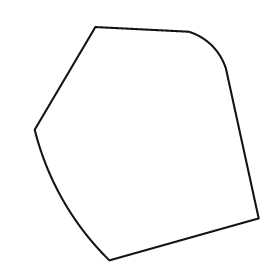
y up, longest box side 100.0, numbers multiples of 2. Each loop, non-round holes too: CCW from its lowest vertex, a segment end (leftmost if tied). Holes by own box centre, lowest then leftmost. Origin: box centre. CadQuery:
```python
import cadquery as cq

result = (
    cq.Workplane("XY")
    .moveTo(-16.0, -50.0)
    .lineTo(48.0, -32.0)
    .lineTo(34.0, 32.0)
    .threePointArc((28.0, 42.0), (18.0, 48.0))
    .lineTo(-22.0, 50.0)
    .lineTo(-48.0, 6.0)
    .threePointArc((-36.0, -24.0), (-16.0, -50.0))
    .close()
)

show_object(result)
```